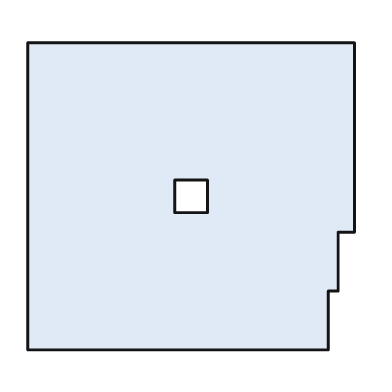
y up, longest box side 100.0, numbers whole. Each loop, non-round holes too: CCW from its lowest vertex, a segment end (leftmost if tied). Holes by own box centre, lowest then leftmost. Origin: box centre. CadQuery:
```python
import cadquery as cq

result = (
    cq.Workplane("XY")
    .moveTo(-50.0, -47.0)
    .lineTo(42.0, -47.0)
    .lineTo(42.0, -29.0)
    .lineTo(45.0, -29.0)
    .lineTo(45.0, -11.0)
    .lineTo(50.0, -11.0)
    .lineTo(50.0, 47.0)
    .lineTo(-50.0, 47.0)
    .close()
    .moveTo(-5.0, -5.0)
    .lineTo(5.0, -5.0)
    .lineTo(5.0, 5.0)
    .lineTo(-5.0, 5.0)
    .close()
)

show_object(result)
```